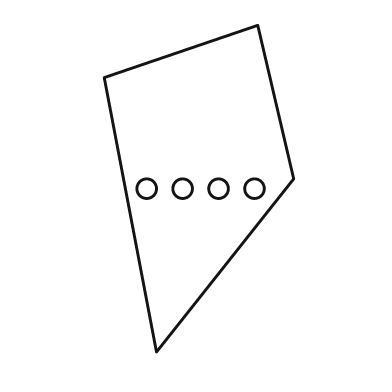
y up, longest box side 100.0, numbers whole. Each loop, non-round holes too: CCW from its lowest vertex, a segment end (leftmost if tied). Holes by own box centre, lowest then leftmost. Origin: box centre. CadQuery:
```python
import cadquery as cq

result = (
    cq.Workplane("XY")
    .moveTo(-13.0, -50.0)
    .lineTo(29.0, 3.0)
    .lineTo(18.0, 50.0)
    .lineTo(-29.0, 34.0)
    .close()
    .moveTo(-16.0, 0.0)
    .circle(3.0)
    .moveTo(-5.0, 0.0)
    .circle(3.0)
    .moveTo(6.0, 0.0)
    .circle(3.0)
    .moveTo(17.0, 0.0)
    .circle(3.0)
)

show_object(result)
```